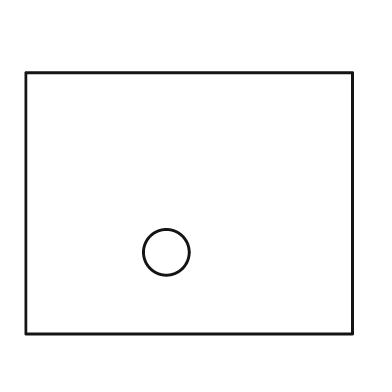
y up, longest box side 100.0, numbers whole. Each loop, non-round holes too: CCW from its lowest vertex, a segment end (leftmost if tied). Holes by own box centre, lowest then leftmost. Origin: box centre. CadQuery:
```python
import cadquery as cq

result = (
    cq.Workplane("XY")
    .moveTo(-50.0, -40.0)
    .lineTo(50.0, -40.0)
    .lineTo(50.0, 40.0)
    .lineTo(-50.0, 40.0)
    .close()
    .moveTo(-7.0, -15.0)
    .circle(7.0)
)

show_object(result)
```